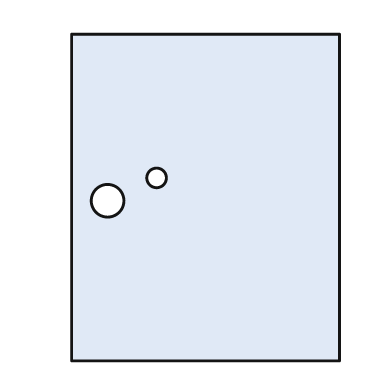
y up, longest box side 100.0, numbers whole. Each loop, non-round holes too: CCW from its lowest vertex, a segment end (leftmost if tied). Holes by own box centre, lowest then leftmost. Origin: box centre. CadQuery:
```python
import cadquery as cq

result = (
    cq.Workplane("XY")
    .moveTo(-41.0, -50.0)
    .lineTo(41.0, -50.0)
    .lineTo(41.0, 50.0)
    .lineTo(-41.0, 50.0)
    .close()
    .moveTo(-30.0, -1.0)
    .circle(5.0)
    .moveTo(-15.0, 6.0)
    .circle(3.0)
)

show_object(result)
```